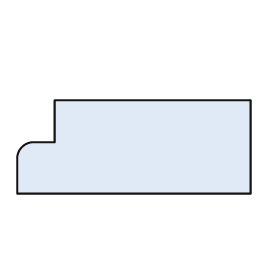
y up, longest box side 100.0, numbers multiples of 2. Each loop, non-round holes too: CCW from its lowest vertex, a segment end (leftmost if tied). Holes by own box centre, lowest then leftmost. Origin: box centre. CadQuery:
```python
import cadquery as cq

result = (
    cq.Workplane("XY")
    .moveTo(-50.0, -20.0)
    .lineTo(50.0, -20.0)
    .lineTo(50.0, 20.0)
    .lineTo(-34.0, 20.0)
    .lineTo(-34.0, 2.0)
    .lineTo(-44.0, 2.0)
    .threePointArc((-48.0, 0.0), (-50.0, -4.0))
    .close()
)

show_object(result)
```